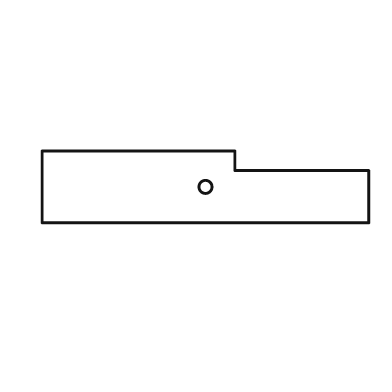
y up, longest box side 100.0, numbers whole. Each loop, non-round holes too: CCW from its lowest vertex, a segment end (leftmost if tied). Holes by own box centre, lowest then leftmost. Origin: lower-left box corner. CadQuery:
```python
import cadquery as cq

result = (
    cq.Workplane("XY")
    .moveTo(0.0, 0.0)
    .lineTo(100.0, 0.0)
    .lineTo(100.0, 16.0)
    .lineTo(59.0, 16.0)
    .lineTo(59.0, 22.0)
    .lineTo(0.0, 22.0)
    .close()
    .moveTo(50.0, 11.0)
    .circle(2.0)
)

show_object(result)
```